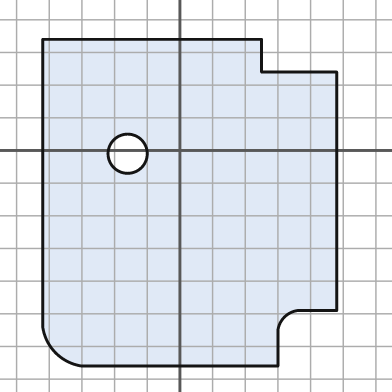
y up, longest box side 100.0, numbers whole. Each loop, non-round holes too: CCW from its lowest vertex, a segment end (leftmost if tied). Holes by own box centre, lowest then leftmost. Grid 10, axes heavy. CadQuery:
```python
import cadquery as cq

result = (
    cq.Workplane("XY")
    .moveTo(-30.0, -66.0)
    .lineTo(30.0, -66.0)
    .lineTo(30.0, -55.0)
    .threePointArc((32.0, -51.0), (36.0, -49.0))
    .lineTo(48.0, -49.0)
    .lineTo(48.0, 24.0)
    .lineTo(25.0, 24.0)
    .lineTo(25.0, 34.0)
    .lineTo(-42.0, 34.0)
    .lineTo(-42.0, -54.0)
    .threePointArc((-38.0, -62.0), (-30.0, -66.0))
    .close()
    .moveTo(-16.0, -1.0)
    .circle(6.0)
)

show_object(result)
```